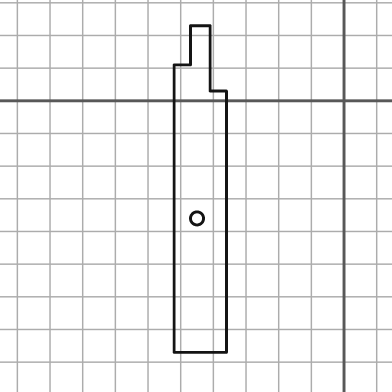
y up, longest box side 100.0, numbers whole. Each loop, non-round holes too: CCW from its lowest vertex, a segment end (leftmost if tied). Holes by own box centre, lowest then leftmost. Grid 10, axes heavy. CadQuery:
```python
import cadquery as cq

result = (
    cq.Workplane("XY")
    .moveTo(-52.0, -77.0)
    .lineTo(-36.0, -77.0)
    .lineTo(-36.0, 3.0)
    .lineTo(-41.0, 3.0)
    .lineTo(-41.0, 23.0)
    .lineTo(-47.0, 23.0)
    .lineTo(-47.0, 11.0)
    .lineTo(-52.0, 11.0)
    .close()
    .moveTo(-45.0, -36.0)
    .circle(2.0)
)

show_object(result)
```